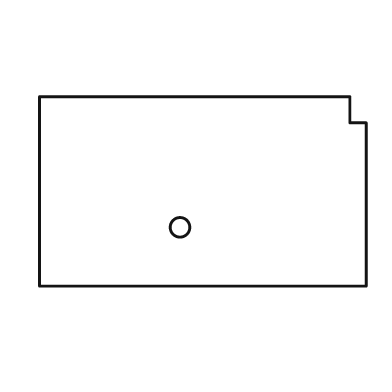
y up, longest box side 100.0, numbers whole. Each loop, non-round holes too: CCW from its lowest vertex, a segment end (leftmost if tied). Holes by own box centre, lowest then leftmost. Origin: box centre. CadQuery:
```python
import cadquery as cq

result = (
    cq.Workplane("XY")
    .moveTo(-50.0, -29.0)
    .lineTo(50.0, -29.0)
    .lineTo(50.0, 21.0)
    .lineTo(45.0, 21.0)
    .lineTo(45.0, 29.0)
    .lineTo(-50.0, 29.0)
    .close()
    .moveTo(-7.0, -11.0)
    .circle(3.0)
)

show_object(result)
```